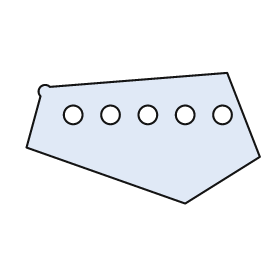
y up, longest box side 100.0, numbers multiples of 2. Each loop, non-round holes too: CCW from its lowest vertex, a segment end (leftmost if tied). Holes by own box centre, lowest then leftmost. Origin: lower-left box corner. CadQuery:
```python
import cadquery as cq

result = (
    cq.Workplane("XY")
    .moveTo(68.0, 0.0)
    .lineTo(100.0, 20.0)
    .lineTo(86.0, 56.0)
    .lineTo(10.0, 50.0)
    .threePointArc((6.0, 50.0), (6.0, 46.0))
    .lineTo(0.0, 24.0)
    .close()
    .moveTo(20.0, 38.0)
    .circle(4.0)
    .moveTo(36.0, 38.0)
    .circle(4.0)
    .moveTo(52.0, 38.0)
    .circle(4.0)
    .moveTo(68.0, 38.0)
    .circle(4.0)
    .moveTo(84.0, 38.0)
    .circle(4.0)
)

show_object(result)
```